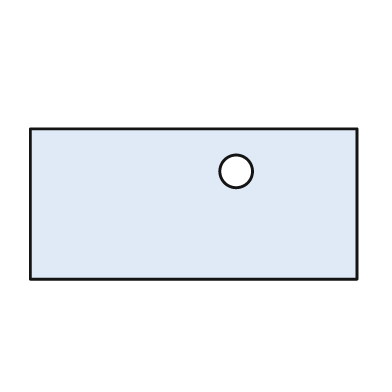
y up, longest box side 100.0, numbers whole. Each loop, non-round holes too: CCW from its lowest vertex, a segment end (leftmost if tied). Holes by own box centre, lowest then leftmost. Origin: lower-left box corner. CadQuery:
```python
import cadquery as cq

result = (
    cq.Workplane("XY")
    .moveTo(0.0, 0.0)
    .lineTo(100.0, 0.0)
    .lineTo(100.0, 46.0)
    .lineTo(0.0, 46.0)
    .close()
    .moveTo(63.0, 33.0)
    .circle(5.0)
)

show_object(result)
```